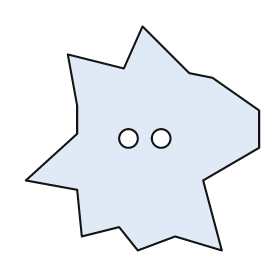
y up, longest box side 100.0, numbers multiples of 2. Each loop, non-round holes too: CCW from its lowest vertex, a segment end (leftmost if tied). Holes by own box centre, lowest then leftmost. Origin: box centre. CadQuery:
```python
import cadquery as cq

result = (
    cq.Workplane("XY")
    .moveTo(-2.0, -48.0)
    .lineTo(14.0, -42.0)
    .lineTo(34.0, -48.0)
    .lineTo(26.0, -18.0)
    .lineTo(50.0, -4.0)
    .lineTo(50.0, 12.0)
    .lineTo(30.0, 26.0)
    .lineTo(20.0, 28.0)
    .lineTo(0.0, 48.0)
    .lineTo(-8.0, 30.0)
    .lineTo(-32.0, 36.0)
    .lineTo(-28.0, 14.0)
    .lineTo(-28.0, 2.0)
    .lineTo(-50.0, -18.0)
    .lineTo(-28.0, -22.0)
    .lineTo(-26.0, -42.0)
    .lineTo(-10.0, -38.0)
    .close()
    .moveTo(-6.0, 0.0)
    .circle(4.0)
    .moveTo(8.0, 0.0)
    .circle(4.0)
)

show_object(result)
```